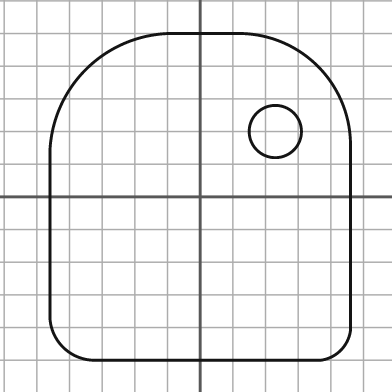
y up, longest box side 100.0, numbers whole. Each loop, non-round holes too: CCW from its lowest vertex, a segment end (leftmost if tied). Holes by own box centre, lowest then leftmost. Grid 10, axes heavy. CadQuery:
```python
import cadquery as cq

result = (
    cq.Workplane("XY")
    .moveTo(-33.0, -50.0)
    .lineTo(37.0, -50.0)
    .threePointArc((43.0, -47.0), (46.0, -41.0))
    .lineTo(46.0, 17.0)
    .threePointArc((36.0, 40.0), (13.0, 50.0))
    .lineTo(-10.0, 50.0)
    .threePointArc((-35.0, 39.0), (-46.0, 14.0))
    .lineTo(-46.0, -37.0)
    .threePointArc((-42.0, -46.0), (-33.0, -50.0))
    .close()
    .moveTo(23.0, 20.0)
    .circle(8.0)
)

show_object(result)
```